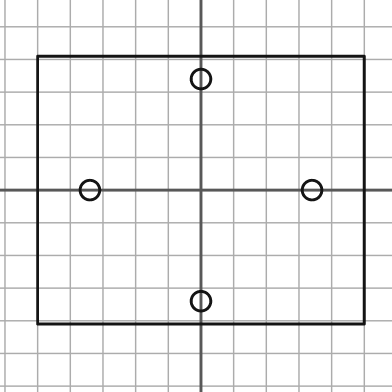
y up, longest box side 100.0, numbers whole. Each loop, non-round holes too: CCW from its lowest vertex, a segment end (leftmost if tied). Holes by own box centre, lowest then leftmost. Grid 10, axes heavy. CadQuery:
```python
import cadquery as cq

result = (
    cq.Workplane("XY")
    .moveTo(-50.0, -41.0)
    .lineTo(50.0, -41.0)
    .lineTo(50.0, 41.0)
    .lineTo(-50.0, 41.0)
    .close()
    .moveTo(0.0, -34.0)
    .circle(3.0)
    .moveTo(-34.0, 0.0)
    .circle(3.0)
    .moveTo(34.0, 0.0)
    .circle(3.0)
    .moveTo(0.0, 34.0)
    .circle(3.0)
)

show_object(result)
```